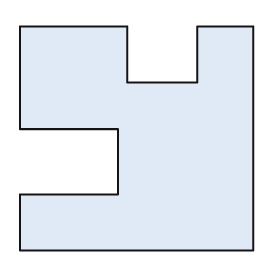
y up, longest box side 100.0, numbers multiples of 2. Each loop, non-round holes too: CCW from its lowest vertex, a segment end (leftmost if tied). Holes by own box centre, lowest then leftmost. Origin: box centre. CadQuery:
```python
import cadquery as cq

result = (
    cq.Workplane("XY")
    .moveTo(-50.0, -48.0)
    .lineTo(50.0, -48.0)
    .lineTo(50.0, 48.0)
    .lineTo(26.0, 48.0)
    .lineTo(26.0, 24.0)
    .lineTo(-4.0, 24.0)
    .lineTo(-4.0, 48.0)
    .lineTo(-50.0, 48.0)
    .lineTo(-50.0, 4.0)
    .lineTo(-8.0, 4.0)
    .lineTo(-8.0, -24.0)
    .lineTo(-50.0, -24.0)
    .close()
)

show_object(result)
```